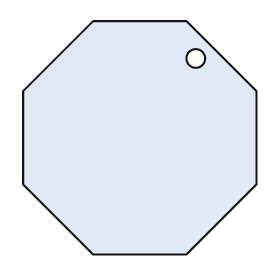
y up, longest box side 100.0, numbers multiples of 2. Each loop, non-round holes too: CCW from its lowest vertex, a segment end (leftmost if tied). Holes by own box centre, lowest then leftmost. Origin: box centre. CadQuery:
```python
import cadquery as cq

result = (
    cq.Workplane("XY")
    .moveTo(-20.0, -50.0)
    .lineTo(20.0, -50.0)
    .lineTo(50.0, -20.0)
    .lineTo(50.0, 20.0)
    .lineTo(20.0, 50.0)
    .lineTo(-20.0, 50.0)
    .lineTo(-50.0, 20.0)
    .lineTo(-50.0, -20.0)
    .close()
    .moveTo(24.0, 34.0)
    .circle(4.0)
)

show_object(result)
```